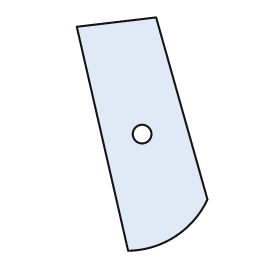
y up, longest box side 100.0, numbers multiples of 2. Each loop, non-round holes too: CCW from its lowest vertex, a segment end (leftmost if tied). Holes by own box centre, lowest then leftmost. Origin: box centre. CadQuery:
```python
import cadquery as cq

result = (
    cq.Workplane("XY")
    .moveTo(-6.0, -50.0)
    .threePointArc((14.0, -44.0), (28.0, -28.0))
    .lineTo(6.0, 50.0)
    .lineTo(-28.0, 46.0)
    .close()
    .moveTo(0.0, 0.0)
    .circle(4.0)
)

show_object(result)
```